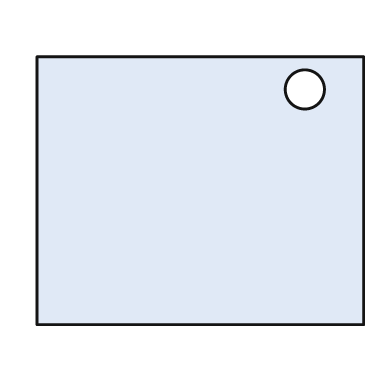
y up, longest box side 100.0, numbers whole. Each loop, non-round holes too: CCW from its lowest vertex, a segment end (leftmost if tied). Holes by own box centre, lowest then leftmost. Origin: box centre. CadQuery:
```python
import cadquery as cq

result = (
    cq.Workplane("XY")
    .moveTo(-50.0, -41.0)
    .lineTo(50.0, -41.0)
    .lineTo(50.0, 41.0)
    .lineTo(-50.0, 41.0)
    .close()
    .moveTo(32.0, 31.0)
    .circle(6.0)
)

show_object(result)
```